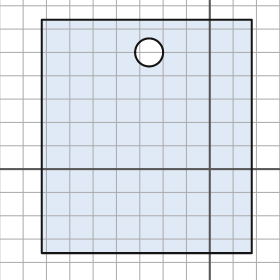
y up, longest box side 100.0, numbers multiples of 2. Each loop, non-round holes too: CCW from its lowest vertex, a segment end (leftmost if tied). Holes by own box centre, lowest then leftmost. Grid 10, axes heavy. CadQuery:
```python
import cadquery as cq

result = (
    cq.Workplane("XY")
    .moveTo(-72.0, -36.0)
    .lineTo(18.0, -36.0)
    .lineTo(18.0, 64.0)
    .lineTo(-72.0, 64.0)
    .close()
    .moveTo(-26.0, 50.0)
    .circle(6.0)
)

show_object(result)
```